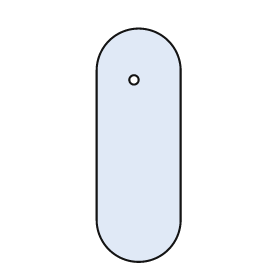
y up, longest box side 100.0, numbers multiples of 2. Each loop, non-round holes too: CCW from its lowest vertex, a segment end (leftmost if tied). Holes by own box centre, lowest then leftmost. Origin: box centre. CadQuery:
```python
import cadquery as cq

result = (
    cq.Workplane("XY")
    .moveTo(-18.0, -32.0)
    .threePointArc((0.0, -50.0), (18.0, -32.0))
    .lineTo(18.0, 32.0)
    .threePointArc((0.0, 50.0), (-18.0, 32.0))
    .close()
    .moveTo(-2.0, 28.0)
    .circle(2.0)
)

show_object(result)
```